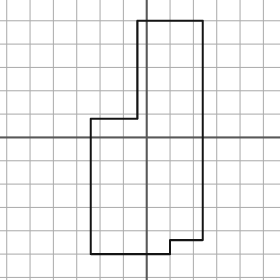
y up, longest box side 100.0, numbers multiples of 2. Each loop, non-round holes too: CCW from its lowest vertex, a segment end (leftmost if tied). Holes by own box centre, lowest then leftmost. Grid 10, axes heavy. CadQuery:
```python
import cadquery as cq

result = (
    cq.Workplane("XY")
    .moveTo(-24.0, -50.0)
    .lineTo(10.0, -50.0)
    .lineTo(10.0, -44.0)
    .lineTo(24.0, -44.0)
    .lineTo(24.0, 50.0)
    .lineTo(-4.0, 50.0)
    .lineTo(-4.0, 8.0)
    .lineTo(-24.0, 8.0)
    .close()
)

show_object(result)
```